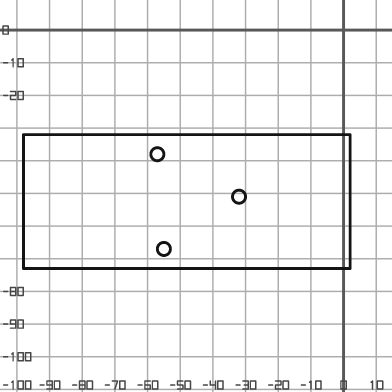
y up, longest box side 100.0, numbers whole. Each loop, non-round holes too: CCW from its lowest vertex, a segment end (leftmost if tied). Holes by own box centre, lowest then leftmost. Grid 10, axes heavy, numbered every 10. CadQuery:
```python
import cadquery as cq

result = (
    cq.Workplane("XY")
    .moveTo(-98.0, -73.0)
    .lineTo(2.0, -73.0)
    .lineTo(2.0, -32.0)
    .lineTo(-98.0, -32.0)
    .close()
    .moveTo(-55.0, -67.0)
    .circle(2.0)
    .moveTo(-32.0, -51.0)
    .circle(2.0)
    .moveTo(-57.0, -38.0)
    .circle(2.0)
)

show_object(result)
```